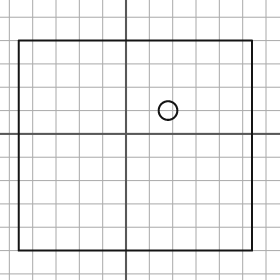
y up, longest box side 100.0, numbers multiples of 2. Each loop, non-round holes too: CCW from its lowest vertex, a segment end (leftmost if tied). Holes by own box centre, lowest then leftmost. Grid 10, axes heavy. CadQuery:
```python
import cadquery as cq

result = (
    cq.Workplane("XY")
    .moveTo(-46.0, -50.0)
    .lineTo(54.0, -50.0)
    .lineTo(54.0, 40.0)
    .lineTo(-46.0, 40.0)
    .close()
    .moveTo(18.0, 10.0)
    .circle(4.0)
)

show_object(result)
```